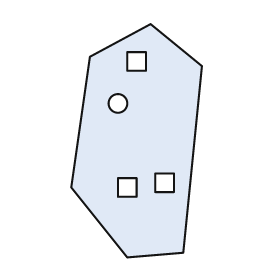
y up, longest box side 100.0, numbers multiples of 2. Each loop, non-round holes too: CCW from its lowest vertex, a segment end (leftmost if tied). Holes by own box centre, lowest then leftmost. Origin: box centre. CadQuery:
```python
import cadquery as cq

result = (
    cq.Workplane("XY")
    .moveTo(-4.0, -50.0)
    .lineTo(20.0, -48.0)
    .lineTo(28.0, 32.0)
    .lineTo(6.0, 50.0)
    .lineTo(-20.0, 36.0)
    .lineTo(-28.0, -20.0)
    .close()
    .moveTo(-8.0, -24.0)
    .lineTo(0.0, -24.0)
    .lineTo(0.0, -16.0)
    .lineTo(-8.0, -16.0)
    .close()
    .moveTo(8.0, -22.0)
    .lineTo(16.0, -22.0)
    .lineTo(16.0, -14.0)
    .lineTo(8.0, -14.0)
    .close()
    .moveTo(-8.0, 16.0)
    .circle(4.0)
    .moveTo(-4.0, 30.0)
    .lineTo(4.0, 30.0)
    .lineTo(4.0, 38.0)
    .lineTo(-4.0, 38.0)
    .close()
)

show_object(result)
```